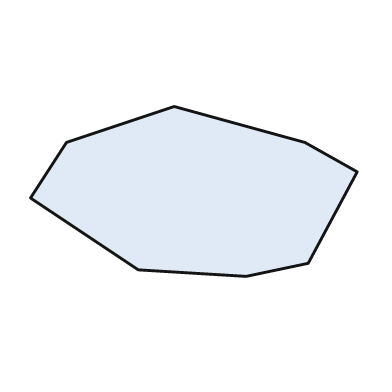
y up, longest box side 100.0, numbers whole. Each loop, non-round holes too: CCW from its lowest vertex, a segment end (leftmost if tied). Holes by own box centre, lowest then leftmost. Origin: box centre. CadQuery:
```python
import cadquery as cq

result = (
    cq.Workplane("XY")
    .moveTo(16.0, -26.0)
    .lineTo(35.0, -22.0)
    .lineTo(50.0, 6.0)
    .lineTo(34.0, 15.0)
    .lineTo(-6.0, 26.0)
    .lineTo(-39.0, 15.0)
    .lineTo(-50.0, -2.0)
    .lineTo(-17.0, -24.0)
    .close()
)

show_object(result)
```